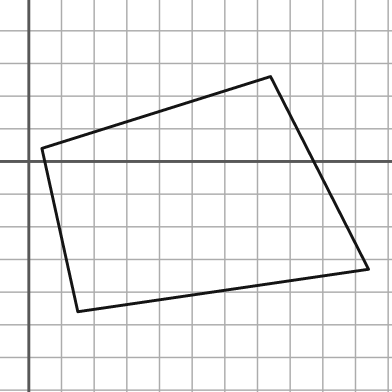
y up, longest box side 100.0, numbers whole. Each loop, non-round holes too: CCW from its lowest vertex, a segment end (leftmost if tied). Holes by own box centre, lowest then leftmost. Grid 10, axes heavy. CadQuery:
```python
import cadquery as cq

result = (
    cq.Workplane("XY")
    .moveTo(15.0, -46.0)
    .lineTo(104.0, -33.0)
    .lineTo(74.0, 26.0)
    .lineTo(4.0, 4.0)
    .close()
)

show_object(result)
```